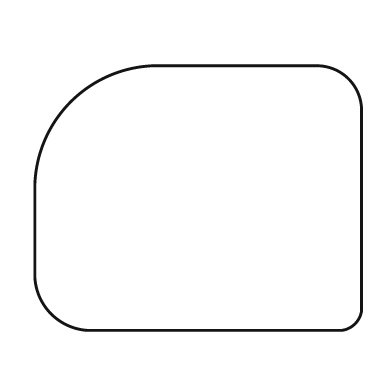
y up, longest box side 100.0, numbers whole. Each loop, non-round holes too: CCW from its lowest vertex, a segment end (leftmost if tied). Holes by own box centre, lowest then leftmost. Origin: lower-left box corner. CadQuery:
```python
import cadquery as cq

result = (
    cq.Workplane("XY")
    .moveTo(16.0, 0.0)
    .lineTo(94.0, 0.0)
    .threePointArc((98.0, 2.0), (100.0, 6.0))
    .lineTo(100.0, 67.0)
    .threePointArc((96.0, 77.0), (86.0, 81.0))
    .lineTo(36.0, 81.0)
    .threePointArc((11.0, 70.0), (0.0, 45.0))
    .lineTo(0.0, 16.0)
    .threePointArc((5.0, 5.0), (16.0, 0.0))
    .close()
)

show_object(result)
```